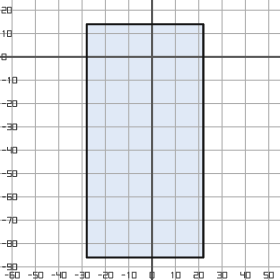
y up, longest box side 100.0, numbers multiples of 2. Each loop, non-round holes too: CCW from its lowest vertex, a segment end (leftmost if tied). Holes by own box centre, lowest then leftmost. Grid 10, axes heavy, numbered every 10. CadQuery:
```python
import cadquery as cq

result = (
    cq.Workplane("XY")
    .moveTo(-28.0, -86.0)
    .lineTo(22.0, -86.0)
    .lineTo(22.0, 14.0)
    .lineTo(-28.0, 14.0)
    .close()
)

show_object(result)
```